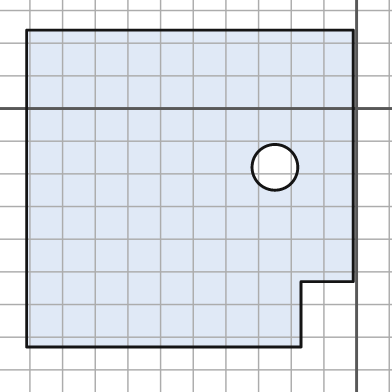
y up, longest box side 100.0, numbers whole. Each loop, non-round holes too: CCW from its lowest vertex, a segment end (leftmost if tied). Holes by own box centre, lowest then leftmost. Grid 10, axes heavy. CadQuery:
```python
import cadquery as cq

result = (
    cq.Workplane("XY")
    .moveTo(-101.0, -73.0)
    .lineTo(-17.0, -73.0)
    .lineTo(-17.0, -53.0)
    .lineTo(-1.0, -53.0)
    .lineTo(-1.0, 24.0)
    .lineTo(-101.0, 24.0)
    .close()
    .moveTo(-25.0, -18.0)
    .circle(7.0)
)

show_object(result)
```